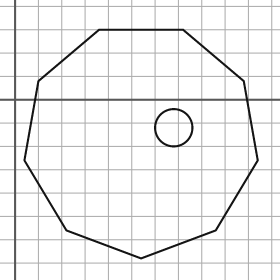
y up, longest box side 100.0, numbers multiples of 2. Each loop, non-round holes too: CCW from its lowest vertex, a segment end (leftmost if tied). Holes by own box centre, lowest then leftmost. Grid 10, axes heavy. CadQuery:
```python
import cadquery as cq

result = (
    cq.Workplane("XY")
    .moveTo(54.0, -68.0)
    .lineTo(86.0, -56.0)
    .lineTo(104.0, -26.0)
    .lineTo(98.0, 8.0)
    .lineTo(72.0, 30.0)
    .lineTo(36.0, 30.0)
    .lineTo(10.0, 8.0)
    .lineTo(4.0, -26.0)
    .lineTo(22.0, -56.0)
    .close()
    .moveTo(68.0, -12.0)
    .circle(8.0)
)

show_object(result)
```